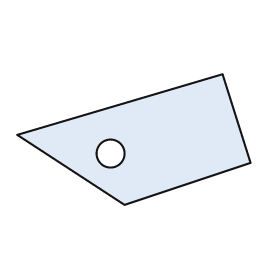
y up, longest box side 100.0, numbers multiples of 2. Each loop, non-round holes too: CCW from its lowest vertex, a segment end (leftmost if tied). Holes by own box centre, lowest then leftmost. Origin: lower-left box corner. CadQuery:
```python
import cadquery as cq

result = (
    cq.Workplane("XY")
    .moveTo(46.0, 0.0)
    .lineTo(100.0, 18.0)
    .lineTo(88.0, 56.0)
    .lineTo(0.0, 30.0)
    .close()
    .moveTo(40.0, 22.0)
    .circle(6.0)
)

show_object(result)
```